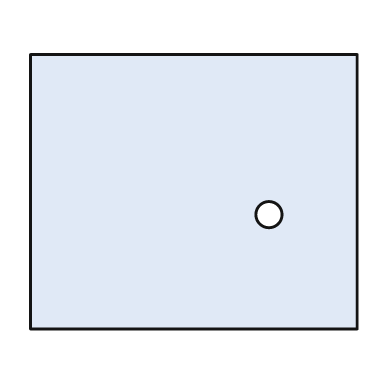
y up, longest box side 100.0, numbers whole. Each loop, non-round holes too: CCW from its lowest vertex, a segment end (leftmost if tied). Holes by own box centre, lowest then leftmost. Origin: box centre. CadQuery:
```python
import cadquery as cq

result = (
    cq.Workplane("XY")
    .moveTo(-50.0, -42.0)
    .lineTo(50.0, -42.0)
    .lineTo(50.0, 42.0)
    .lineTo(-50.0, 42.0)
    .close()
    .moveTo(23.0, -7.0)
    .circle(4.0)
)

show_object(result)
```